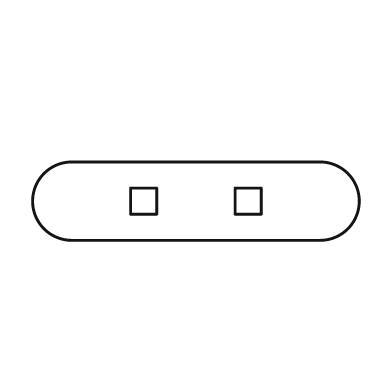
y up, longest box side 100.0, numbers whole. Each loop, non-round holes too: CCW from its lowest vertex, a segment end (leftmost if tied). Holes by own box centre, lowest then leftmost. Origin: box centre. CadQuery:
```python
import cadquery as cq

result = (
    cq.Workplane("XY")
    .moveTo(-38.0, -12.0)
    .lineTo(38.0, -12.0)
    .threePointArc((50.0, 0.0), (38.0, 12.0))
    .lineTo(-38.0, 12.0)
    .threePointArc((-50.0, 0.0), (-38.0, -12.0))
    .close()
    .moveTo(-20.0, -4.0)
    .lineTo(-12.0, -4.0)
    .lineTo(-12.0, 4.0)
    .lineTo(-20.0, 4.0)
    .close()
    .moveTo(12.0, -4.0)
    .lineTo(20.0, -4.0)
    .lineTo(20.0, 4.0)
    .lineTo(12.0, 4.0)
    .close()
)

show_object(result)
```